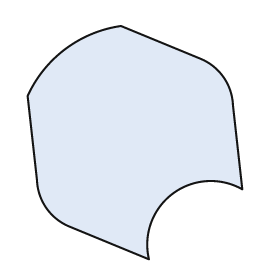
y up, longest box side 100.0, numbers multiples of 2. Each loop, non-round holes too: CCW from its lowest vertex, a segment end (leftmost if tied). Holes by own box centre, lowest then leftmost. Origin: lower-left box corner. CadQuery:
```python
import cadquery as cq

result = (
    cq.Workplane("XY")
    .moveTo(52.0, 0.0)
    .threePointArc((62.0, 28.0), (92.0, 30.0))
    .lineTo(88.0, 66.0)
    .threePointArc((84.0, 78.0), (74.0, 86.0))
    .lineTo(40.0, 100.0)
    .threePointArc((16.0, 90.0), (0.0, 70.0))
    .lineTo(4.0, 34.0)
    .threePointArc((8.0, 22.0), (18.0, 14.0))
    .close()
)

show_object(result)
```